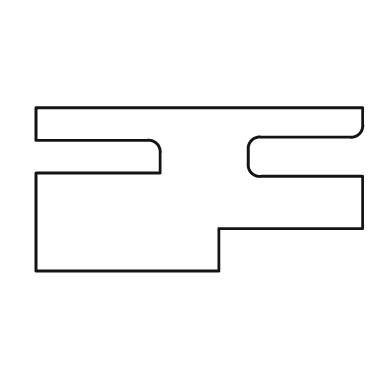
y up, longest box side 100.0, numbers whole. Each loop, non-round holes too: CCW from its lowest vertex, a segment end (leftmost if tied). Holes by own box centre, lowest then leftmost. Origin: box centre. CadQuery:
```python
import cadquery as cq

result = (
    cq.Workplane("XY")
    .moveTo(-50.0, -25.0)
    .lineTo(6.0, -25.0)
    .lineTo(6.0, -12.0)
    .lineTo(50.0, -12.0)
    .lineTo(50.0, 4.0)
    .lineTo(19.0, 4.0)
    .threePointArc((16.0, 5.0), (15.0, 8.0))
    .lineTo(15.0, 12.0)
    .threePointArc((16.0, 15.0), (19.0, 16.0))
    .lineTo(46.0, 16.0)
    .threePointArc((49.0, 17.0), (50.0, 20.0))
    .lineTo(50.0, 25.0)
    .lineTo(-50.0, 25.0)
    .lineTo(-50.0, 15.0)
    .lineTo(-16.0, 15.0)
    .threePointArc((-13.0, 14.0), (-12.0, 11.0))
    .lineTo(-12.0, 5.0)
    .lineTo(-50.0, 5.0)
    .close()
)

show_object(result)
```